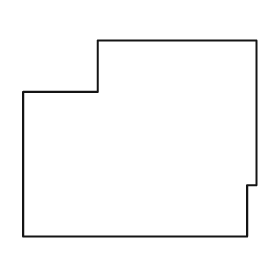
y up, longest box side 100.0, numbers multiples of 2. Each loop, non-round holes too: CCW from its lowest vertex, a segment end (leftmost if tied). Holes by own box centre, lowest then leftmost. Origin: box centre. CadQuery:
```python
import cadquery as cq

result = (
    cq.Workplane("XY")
    .moveTo(-50.0, -42.0)
    .lineTo(46.0, -42.0)
    .lineTo(46.0, -20.0)
    .lineTo(50.0, -20.0)
    .lineTo(50.0, 42.0)
    .lineTo(-18.0, 42.0)
    .lineTo(-18.0, 20.0)
    .lineTo(-50.0, 20.0)
    .close()
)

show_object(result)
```